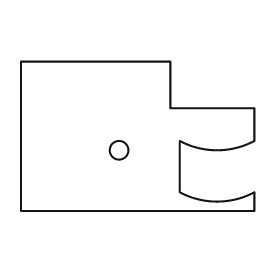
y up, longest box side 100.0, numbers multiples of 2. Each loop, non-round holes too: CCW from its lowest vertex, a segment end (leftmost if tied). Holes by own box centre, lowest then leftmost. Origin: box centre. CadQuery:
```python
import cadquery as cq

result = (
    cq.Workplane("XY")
    .moveTo(-50.0, -32.0)
    .lineTo(50.0, -32.0)
    .lineTo(50.0, -24.0)
    .threePointArc((34.0, -28.0), (18.0, -24.0))
    .lineTo(18.0, -2.0)
    .threePointArc((34.0, -6.0), (50.0, -2.0))
    .lineTo(50.0, 12.0)
    .lineTo(14.0, 12.0)
    .lineTo(14.0, 32.0)
    .lineTo(-50.0, 32.0)
    .close()
    .moveTo(-8.0, -6.0)
    .circle(4.0)
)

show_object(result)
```